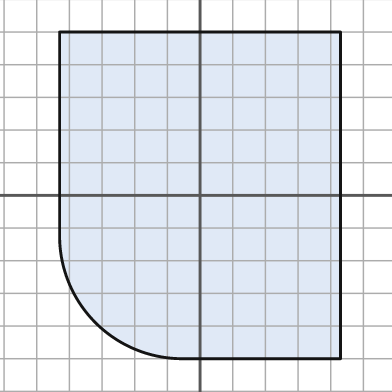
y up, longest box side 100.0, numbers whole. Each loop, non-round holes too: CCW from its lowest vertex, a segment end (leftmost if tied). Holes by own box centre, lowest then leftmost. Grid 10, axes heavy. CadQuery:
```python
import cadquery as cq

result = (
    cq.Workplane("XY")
    .moveTo(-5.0, -50.0)
    .lineTo(43.0, -50.0)
    .lineTo(43.0, 50.0)
    .lineTo(-43.0, 50.0)
    .lineTo(-43.0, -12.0)
    .threePointArc((-32.0, -39.0), (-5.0, -50.0))
    .close()
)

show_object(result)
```